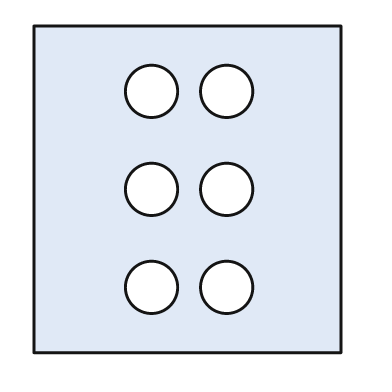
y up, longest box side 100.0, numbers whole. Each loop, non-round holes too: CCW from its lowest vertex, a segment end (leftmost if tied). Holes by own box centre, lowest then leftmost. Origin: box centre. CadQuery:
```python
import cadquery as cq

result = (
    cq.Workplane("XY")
    .moveTo(-47.0, -50.0)
    .lineTo(47.0, -50.0)
    .lineTo(47.0, 50.0)
    .lineTo(-47.0, 50.0)
    .close()
    .moveTo(-11.0, -30.0)
    .circle(8.0)
    .moveTo(12.0, -30.0)
    .circle(8.0)
    .moveTo(-11.0, 0.0)
    .circle(8.0)
    .moveTo(12.0, 0.0)
    .circle(8.0)
    .moveTo(-11.0, 30.0)
    .circle(8.0)
    .moveTo(12.0, 30.0)
    .circle(8.0)
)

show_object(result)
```